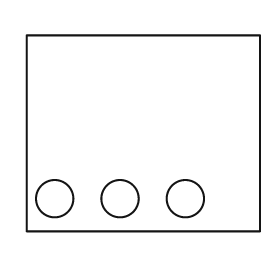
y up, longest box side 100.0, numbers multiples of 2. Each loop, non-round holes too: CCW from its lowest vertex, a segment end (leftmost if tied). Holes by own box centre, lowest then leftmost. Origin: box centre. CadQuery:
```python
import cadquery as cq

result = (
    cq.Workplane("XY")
    .moveTo(-50.0, -42.0)
    .lineTo(50.0, -42.0)
    .lineTo(50.0, 42.0)
    .lineTo(-50.0, 42.0)
    .close()
    .moveTo(-38.0, -28.0)
    .circle(8.0)
    .moveTo(-10.0, -28.0)
    .circle(8.0)
    .moveTo(18.0, -28.0)
    .circle(8.0)
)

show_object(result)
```